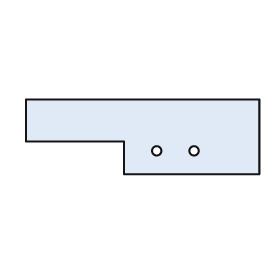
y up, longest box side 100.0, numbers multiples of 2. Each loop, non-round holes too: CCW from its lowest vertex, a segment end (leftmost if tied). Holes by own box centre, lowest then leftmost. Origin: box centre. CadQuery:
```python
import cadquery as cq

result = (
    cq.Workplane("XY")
    .moveTo(-8.0, -16.0)
    .lineTo(50.0, -16.0)
    .lineTo(50.0, 16.0)
    .lineTo(-50.0, 16.0)
    .lineTo(-50.0, -2.0)
    .lineTo(-8.0, -2.0)
    .close()
    .moveTo(6.0, -6.0)
    .circle(2.0)
    .moveTo(22.0, -6.0)
    .circle(2.0)
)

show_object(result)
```